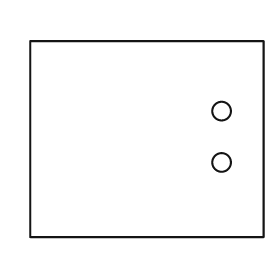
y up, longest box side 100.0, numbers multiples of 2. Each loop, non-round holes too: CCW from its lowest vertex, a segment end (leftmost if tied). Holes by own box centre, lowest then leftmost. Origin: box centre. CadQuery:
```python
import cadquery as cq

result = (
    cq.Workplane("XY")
    .moveTo(-50.0, -42.0)
    .lineTo(50.0, -42.0)
    .lineTo(50.0, 42.0)
    .lineTo(-50.0, 42.0)
    .close()
    .moveTo(32.0, -10.0)
    .circle(4.0)
    .moveTo(32.0, 12.0)
    .circle(4.0)
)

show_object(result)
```